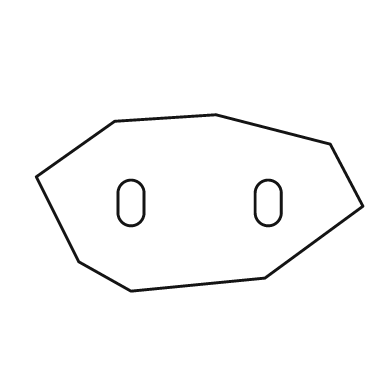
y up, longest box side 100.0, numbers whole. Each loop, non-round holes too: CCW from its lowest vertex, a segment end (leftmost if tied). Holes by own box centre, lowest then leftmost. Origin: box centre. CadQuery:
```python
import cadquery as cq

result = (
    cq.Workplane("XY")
    .moveTo(-21.0, -27.0)
    .lineTo(20.0, -23.0)
    .lineTo(50.0, -1.0)
    .lineTo(40.0, 18.0)
    .lineTo(5.0, 27.0)
    .lineTo(-26.0, 25.0)
    .lineTo(-50.0, 8.0)
    .lineTo(-37.0, -18.0)
    .close()
    .moveTo(-25.0, -3.0)
    .threePointArc((-21.0, -7.0), (-17.0, -3.0))
    .lineTo(-17.0, 3.0)
    .threePointArc((-21.0, 7.0), (-25.0, 3.0))
    .close()
    .moveTo(17.0, -3.0)
    .threePointArc((21.0, -7.0), (25.0, -3.0))
    .lineTo(25.0, 3.0)
    .threePointArc((21.0, 7.0), (17.0, 3.0))
    .close()
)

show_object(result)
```